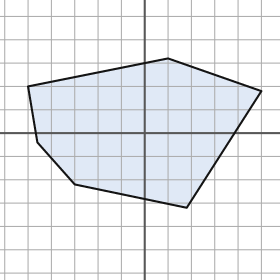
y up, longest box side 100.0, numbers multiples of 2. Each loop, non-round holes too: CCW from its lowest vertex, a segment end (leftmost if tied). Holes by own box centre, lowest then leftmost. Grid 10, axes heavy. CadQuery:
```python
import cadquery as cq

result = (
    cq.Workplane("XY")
    .moveTo(18.0, -32.0)
    .lineTo(50.0, 18.0)
    .lineTo(10.0, 32.0)
    .lineTo(-50.0, 20.0)
    .lineTo(-46.0, -4.0)
    .lineTo(-30.0, -22.0)
    .close()
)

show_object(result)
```